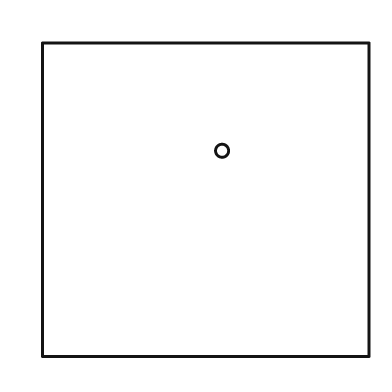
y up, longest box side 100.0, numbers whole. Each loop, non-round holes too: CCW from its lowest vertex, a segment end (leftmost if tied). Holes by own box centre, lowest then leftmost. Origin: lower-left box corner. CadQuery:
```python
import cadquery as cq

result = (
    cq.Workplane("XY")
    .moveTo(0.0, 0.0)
    .lineTo(100.0, 0.0)
    .lineTo(100.0, 96.0)
    .lineTo(0.0, 96.0)
    .close()
    .moveTo(55.0, 63.0)
    .circle(2.0)
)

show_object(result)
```